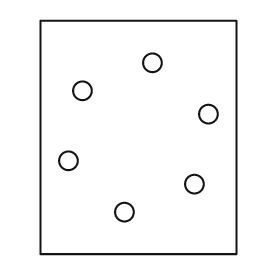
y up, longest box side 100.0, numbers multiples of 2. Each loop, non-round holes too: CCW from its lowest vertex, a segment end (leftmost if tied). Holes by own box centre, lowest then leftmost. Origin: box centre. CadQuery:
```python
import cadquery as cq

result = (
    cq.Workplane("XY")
    .moveTo(-42.0, -50.0)
    .lineTo(42.0, -50.0)
    .lineTo(42.0, 50.0)
    .lineTo(-42.0, 50.0)
    .close()
    .moveTo(-6.0, -32.0)
    .circle(4.0)
    .moveTo(24.0, -20.0)
    .circle(4.0)
    .moveTo(-30.0, -10.0)
    .circle(4.0)
    .moveTo(30.0, 10.0)
    .circle(4.0)
    .moveTo(-24.0, 20.0)
    .circle(4.0)
    .moveTo(6.0, 32.0)
    .circle(4.0)
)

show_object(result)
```